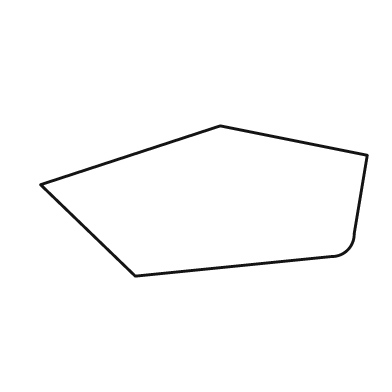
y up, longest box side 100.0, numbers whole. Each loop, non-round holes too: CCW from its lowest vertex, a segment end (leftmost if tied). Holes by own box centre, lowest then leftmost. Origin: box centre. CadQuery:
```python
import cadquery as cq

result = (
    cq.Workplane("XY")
    .moveTo(-21.0, -23.0)
    .lineTo(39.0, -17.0)
    .threePointArc((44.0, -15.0), (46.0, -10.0))
    .lineTo(50.0, 14.0)
    .lineTo(5.0, 23.0)
    .lineTo(-50.0, 5.0)
    .close()
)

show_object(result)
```